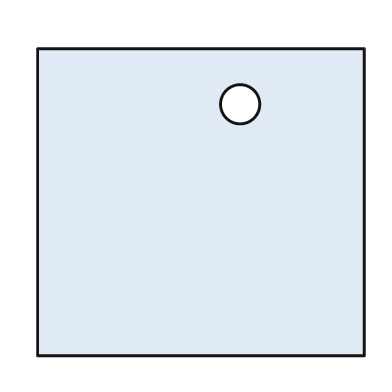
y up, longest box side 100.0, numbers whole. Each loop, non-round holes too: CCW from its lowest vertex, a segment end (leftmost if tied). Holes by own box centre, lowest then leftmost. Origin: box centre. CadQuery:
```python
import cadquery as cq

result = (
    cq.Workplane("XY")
    .moveTo(-50.0, -47.0)
    .lineTo(50.0, -47.0)
    .lineTo(50.0, 47.0)
    .lineTo(-50.0, 47.0)
    .close()
    .moveTo(12.0, 30.0)
    .circle(6.0)
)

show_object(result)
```